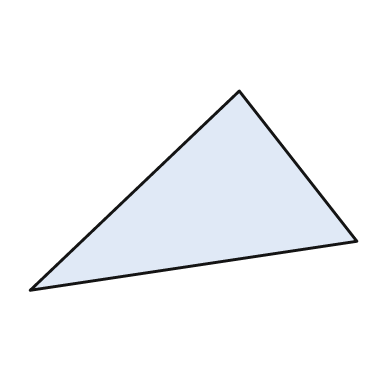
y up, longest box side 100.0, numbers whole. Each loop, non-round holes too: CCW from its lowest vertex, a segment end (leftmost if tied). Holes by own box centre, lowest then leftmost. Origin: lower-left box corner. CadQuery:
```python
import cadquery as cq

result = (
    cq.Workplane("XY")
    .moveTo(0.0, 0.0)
    .lineTo(100.0, 15.0)
    .lineTo(64.0, 61.0)
    .close()
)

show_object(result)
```